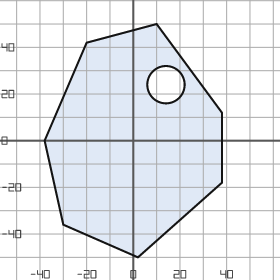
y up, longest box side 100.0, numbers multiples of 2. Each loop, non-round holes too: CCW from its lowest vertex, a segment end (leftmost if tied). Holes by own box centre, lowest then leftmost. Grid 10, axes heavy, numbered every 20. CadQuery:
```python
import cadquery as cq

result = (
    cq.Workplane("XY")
    .moveTo(2.0, -50.0)
    .lineTo(38.0, -18.0)
    .lineTo(38.0, 12.0)
    .lineTo(10.0, 50.0)
    .lineTo(-20.0, 42.0)
    .lineTo(-38.0, 0.0)
    .lineTo(-30.0, -36.0)
    .close()
    .moveTo(14.0, 24.0)
    .circle(8.0)
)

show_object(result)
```